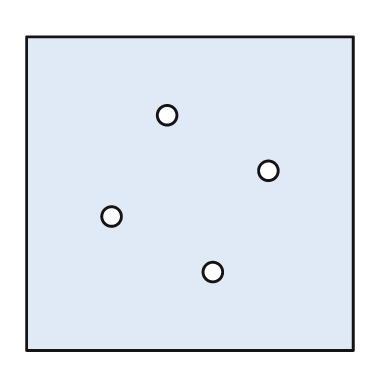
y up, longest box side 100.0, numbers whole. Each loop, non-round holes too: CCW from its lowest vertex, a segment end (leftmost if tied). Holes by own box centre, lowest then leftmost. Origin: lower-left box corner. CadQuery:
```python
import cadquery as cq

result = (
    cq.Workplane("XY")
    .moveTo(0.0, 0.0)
    .lineTo(100.0, 0.0)
    .lineTo(100.0, 96.0)
    .lineTo(0.0, 96.0)
    .close()
    .moveTo(57.0, 24.0)
    .circle(3.0)
    .moveTo(26.0, 41.0)
    .circle(3.0)
    .moveTo(74.0, 55.0)
    .circle(3.0)
    .moveTo(43.0, 72.0)
    .circle(3.0)
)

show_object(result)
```